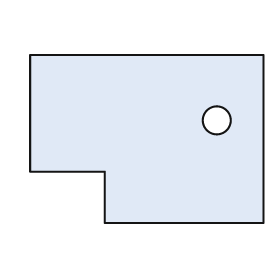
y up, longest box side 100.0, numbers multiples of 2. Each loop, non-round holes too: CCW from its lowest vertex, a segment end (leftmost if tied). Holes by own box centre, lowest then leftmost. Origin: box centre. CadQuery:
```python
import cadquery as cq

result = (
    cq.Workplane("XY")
    .moveTo(-18.0, -36.0)
    .lineTo(50.0, -36.0)
    .lineTo(50.0, 36.0)
    .lineTo(-50.0, 36.0)
    .lineTo(-50.0, -14.0)
    .lineTo(-18.0, -14.0)
    .close()
    .moveTo(30.0, 8.0)
    .circle(6.0)
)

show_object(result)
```